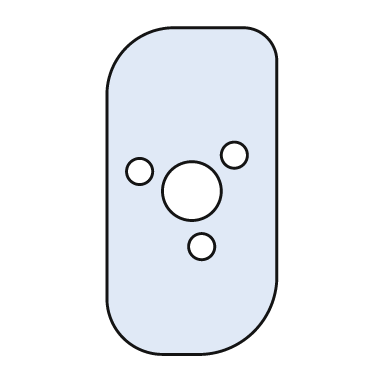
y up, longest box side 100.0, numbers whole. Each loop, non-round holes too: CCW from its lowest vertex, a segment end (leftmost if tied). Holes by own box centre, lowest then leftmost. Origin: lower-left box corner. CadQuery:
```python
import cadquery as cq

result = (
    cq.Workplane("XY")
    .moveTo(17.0, 0.0)
    .lineTo(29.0, 0.0)
    .threePointArc((45.0, 7.0), (52.0, 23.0))
    .lineTo(52.0, 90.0)
    .threePointArc((49.0, 97.0), (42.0, 100.0))
    .lineTo(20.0, 100.0)
    .threePointArc((6.0, 94.0), (0.0, 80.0))
    .lineTo(0.0, 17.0)
    .threePointArc((5.0, 5.0), (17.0, 0.0))
    .close()
    .moveTo(29.0, 33.0)
    .circle(4.0)
    .moveTo(26.0, 50.0)
    .circle(9.0)
    .moveTo(10.0, 56.0)
    .circle(4.0)
    .moveTo(39.0, 61.0)
    .circle(4.0)
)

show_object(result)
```